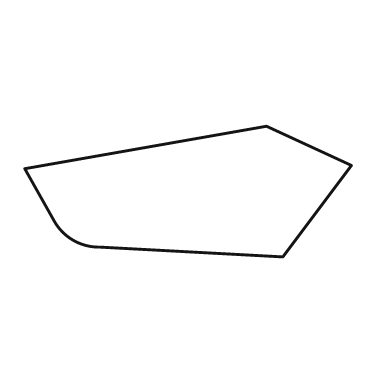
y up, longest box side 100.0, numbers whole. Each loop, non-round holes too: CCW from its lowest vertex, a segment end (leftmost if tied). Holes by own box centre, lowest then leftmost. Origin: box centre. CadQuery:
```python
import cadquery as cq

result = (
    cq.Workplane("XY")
    .moveTo(29.0, -20.0)
    .lineTo(50.0, 8.0)
    .lineTo(24.0, 20.0)
    .lineTo(-50.0, 7.0)
    .lineTo(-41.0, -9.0)
    .threePointArc((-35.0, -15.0), (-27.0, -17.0))
    .close()
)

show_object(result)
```